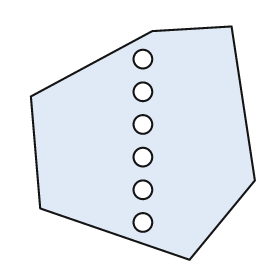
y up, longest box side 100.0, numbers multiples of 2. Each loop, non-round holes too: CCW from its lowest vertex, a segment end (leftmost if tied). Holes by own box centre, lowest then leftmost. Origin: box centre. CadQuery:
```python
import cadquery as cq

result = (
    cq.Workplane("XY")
    .moveTo(20.0, -50.0)
    .lineTo(48.0, -16.0)
    .lineTo(38.0, 50.0)
    .lineTo(4.0, 48.0)
    .lineTo(-48.0, 20.0)
    .lineTo(-44.0, -28.0)
    .close()
    .moveTo(0.0, -34.0)
    .circle(4.0)
    .moveTo(0.0, -20.0)
    .circle(4.0)
    .moveTo(0.0, -6.0)
    .circle(4.0)
    .moveTo(0.0, 8.0)
    .circle(4.0)
    .moveTo(0.0, 22.0)
    .circle(4.0)
    .moveTo(0.0, 36.0)
    .circle(4.0)
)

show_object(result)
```